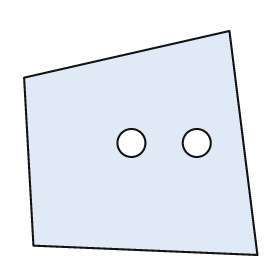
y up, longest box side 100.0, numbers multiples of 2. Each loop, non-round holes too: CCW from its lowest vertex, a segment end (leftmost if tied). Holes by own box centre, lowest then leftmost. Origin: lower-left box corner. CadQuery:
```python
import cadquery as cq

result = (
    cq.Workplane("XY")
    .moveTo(100.0, 0.0)
    .lineTo(88.0, 96.0)
    .lineTo(0.0, 76.0)
    .lineTo(4.0, 4.0)
    .close()
    .moveTo(46.0, 48.0)
    .circle(6.0)
    .moveTo(74.0, 48.0)
    .circle(6.0)
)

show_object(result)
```